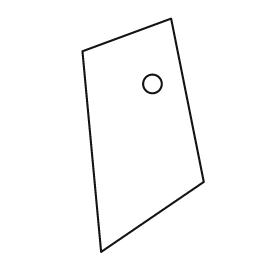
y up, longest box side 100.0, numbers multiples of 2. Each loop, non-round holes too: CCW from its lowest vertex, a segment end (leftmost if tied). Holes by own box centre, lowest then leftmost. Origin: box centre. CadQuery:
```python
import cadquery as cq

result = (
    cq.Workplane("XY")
    .moveTo(-18.0, -50.0)
    .lineTo(26.0, -20.0)
    .lineTo(12.0, 50.0)
    .lineTo(-26.0, 36.0)
    .close()
    .moveTo(4.0, 22.0)
    .circle(4.0)
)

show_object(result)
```